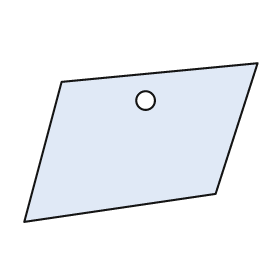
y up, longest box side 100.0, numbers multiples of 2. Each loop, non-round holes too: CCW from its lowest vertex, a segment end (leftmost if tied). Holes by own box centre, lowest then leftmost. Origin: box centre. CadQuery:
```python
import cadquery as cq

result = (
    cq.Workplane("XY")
    .moveTo(-50.0, -34.0)
    .lineTo(32.0, -22.0)
    .lineTo(50.0, 34.0)
    .lineTo(-34.0, 26.0)
    .close()
    .moveTo(2.0, 18.0)
    .circle(4.0)
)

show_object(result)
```